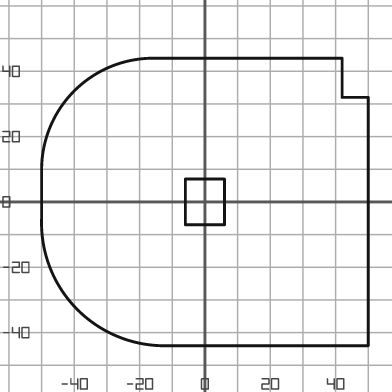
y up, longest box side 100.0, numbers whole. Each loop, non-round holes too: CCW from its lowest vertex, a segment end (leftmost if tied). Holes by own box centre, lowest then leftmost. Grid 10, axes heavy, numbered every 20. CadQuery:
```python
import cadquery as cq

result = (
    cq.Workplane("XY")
    .moveTo(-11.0, -44.0)
    .lineTo(50.0, -44.0)
    .lineTo(50.0, 32.0)
    .lineTo(42.0, 32.0)
    .lineTo(42.0, 44.0)
    .lineTo(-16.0, 44.0)
    .threePointArc((-40.0, 34.0), (-50.0, 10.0))
    .lineTo(-50.0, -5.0)
    .threePointArc((-39.0, -33.0), (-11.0, -44.0))
    .close()
    .moveTo(-6.0, -7.0)
    .lineTo(6.0, -7.0)
    .lineTo(6.0, 7.0)
    .lineTo(-6.0, 7.0)
    .close()
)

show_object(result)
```